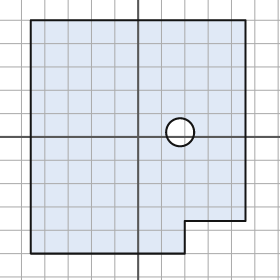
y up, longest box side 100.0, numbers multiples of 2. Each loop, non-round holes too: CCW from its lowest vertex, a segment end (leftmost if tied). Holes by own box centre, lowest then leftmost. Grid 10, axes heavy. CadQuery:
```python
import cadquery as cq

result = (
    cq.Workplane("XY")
    .moveTo(-46.0, -50.0)
    .lineTo(20.0, -50.0)
    .lineTo(20.0, -36.0)
    .lineTo(46.0, -36.0)
    .lineTo(46.0, 50.0)
    .lineTo(-46.0, 50.0)
    .close()
    .moveTo(18.0, 2.0)
    .circle(6.0)
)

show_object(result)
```